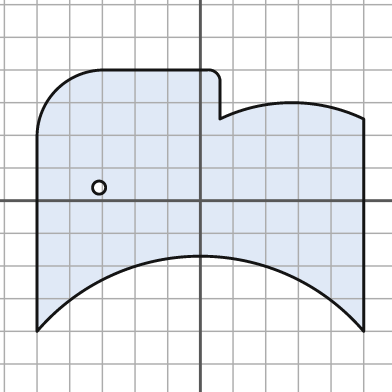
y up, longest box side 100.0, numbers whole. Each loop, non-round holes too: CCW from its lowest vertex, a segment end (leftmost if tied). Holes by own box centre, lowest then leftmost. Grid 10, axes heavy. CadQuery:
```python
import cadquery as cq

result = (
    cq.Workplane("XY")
    .moveTo(-50.0, -40.0)
    .threePointArc((0.0, -17.0), (50.0, -40.0))
    .lineTo(50.0, 25.0)
    .threePointArc((28.0, 30.0), (6.0, 25.0))
    .lineTo(6.0, 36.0)
    .threePointArc((5.0, 39.0), (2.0, 40.0))
    .lineTo(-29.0, 40.0)
    .threePointArc((-44.0, 34.0), (-50.0, 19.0))
    .close()
    .moveTo(-31.0, 4.0)
    .circle(2.0)
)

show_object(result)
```